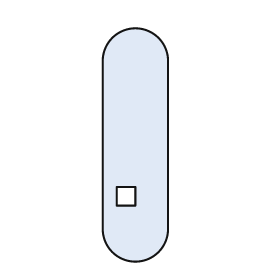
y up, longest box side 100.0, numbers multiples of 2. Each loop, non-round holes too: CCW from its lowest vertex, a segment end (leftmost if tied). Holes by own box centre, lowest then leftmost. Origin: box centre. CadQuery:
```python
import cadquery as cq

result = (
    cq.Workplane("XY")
    .moveTo(-14.0, -36.0)
    .threePointArc((0.0, -50.0), (14.0, -36.0))
    .lineTo(14.0, 36.0)
    .threePointArc((0.0, 50.0), (-14.0, 36.0))
    .close()
    .moveTo(-8.0, -26.0)
    .lineTo(0.0, -26.0)
    .lineTo(0.0, -18.0)
    .lineTo(-8.0, -18.0)
    .close()
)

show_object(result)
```